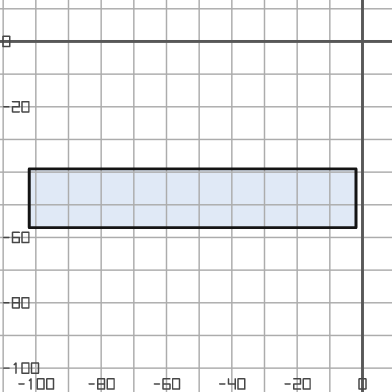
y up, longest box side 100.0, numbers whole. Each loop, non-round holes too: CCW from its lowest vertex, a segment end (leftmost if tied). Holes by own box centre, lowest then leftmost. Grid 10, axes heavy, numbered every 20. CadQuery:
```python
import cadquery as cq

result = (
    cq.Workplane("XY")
    .moveTo(-102.0, -57.0)
    .lineTo(-2.0, -57.0)
    .lineTo(-2.0, -39.0)
    .lineTo(-102.0, -39.0)
    .close()
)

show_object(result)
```